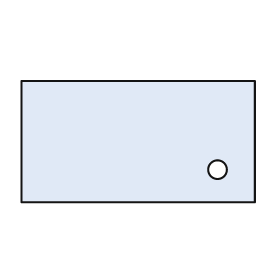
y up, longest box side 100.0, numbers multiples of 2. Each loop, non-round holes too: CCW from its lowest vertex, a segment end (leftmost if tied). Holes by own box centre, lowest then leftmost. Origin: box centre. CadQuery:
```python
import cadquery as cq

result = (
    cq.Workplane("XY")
    .moveTo(-50.0, -26.0)
    .lineTo(50.0, -26.0)
    .lineTo(50.0, 26.0)
    .lineTo(-50.0, 26.0)
    .close()
    .moveTo(34.0, -12.0)
    .circle(4.0)
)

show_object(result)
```